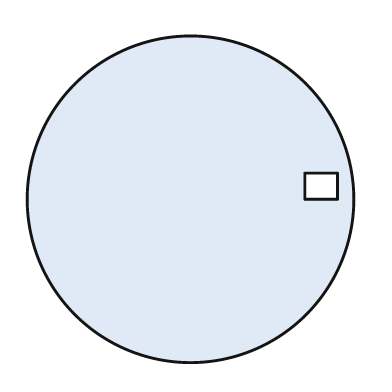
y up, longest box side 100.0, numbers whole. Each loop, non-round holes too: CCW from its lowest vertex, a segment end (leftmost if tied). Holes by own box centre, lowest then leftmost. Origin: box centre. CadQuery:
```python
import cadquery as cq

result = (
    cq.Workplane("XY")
    .moveTo(0.0, 0.0)
    .circle(50.0)
    .moveTo(35.0, 0.0)
    .lineTo(45.0, 0.0)
    .lineTo(45.0, 8.0)
    .lineTo(35.0, 8.0)
    .close()
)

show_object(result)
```